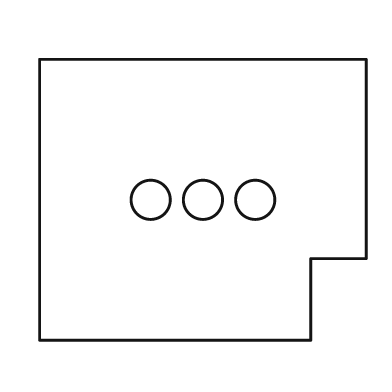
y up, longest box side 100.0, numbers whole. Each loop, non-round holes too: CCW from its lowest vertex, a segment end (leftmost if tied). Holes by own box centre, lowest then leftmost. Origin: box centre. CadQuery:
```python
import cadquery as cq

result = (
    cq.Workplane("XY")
    .moveTo(-50.0, -43.0)
    .lineTo(33.0, -43.0)
    .lineTo(33.0, -18.0)
    .lineTo(50.0, -18.0)
    .lineTo(50.0, 43.0)
    .lineTo(-50.0, 43.0)
    .close()
    .moveTo(-16.0, 0.0)
    .circle(6.0)
    .moveTo(0.0, 0.0)
    .circle(6.0)
    .moveTo(16.0, 0.0)
    .circle(6.0)
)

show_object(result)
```